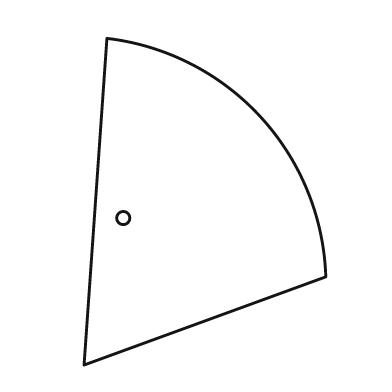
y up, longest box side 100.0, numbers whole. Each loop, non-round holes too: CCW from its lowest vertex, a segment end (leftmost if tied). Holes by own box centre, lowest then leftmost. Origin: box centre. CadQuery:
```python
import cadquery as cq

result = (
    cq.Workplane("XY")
    .moveTo(-37.0, -50.0)
    .lineTo(37.0, -23.0)
    .threePointArc((17.0, 26.0), (-30.0, 50.0))
    .close()
    .moveTo(-25.0, -5.0)
    .circle(2.0)
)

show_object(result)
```